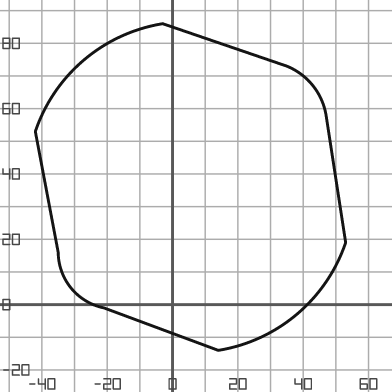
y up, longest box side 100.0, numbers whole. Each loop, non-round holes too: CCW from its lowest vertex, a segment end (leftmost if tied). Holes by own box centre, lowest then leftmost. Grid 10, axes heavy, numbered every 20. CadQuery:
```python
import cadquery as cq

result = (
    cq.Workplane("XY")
    .moveTo(14.0, -14.0)
    .threePointArc((38.0, -3.0), (53.0, 19.0))
    .lineTo(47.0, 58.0)
    .threePointArc((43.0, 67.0), (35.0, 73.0))
    .lineTo(-3.0, 86.0)
    .threePointArc((-27.0, 75.0), (-42.0, 53.0))
    .lineTo(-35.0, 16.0)
    .threePointArc((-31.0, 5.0), (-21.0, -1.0))
    .close()
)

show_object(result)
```